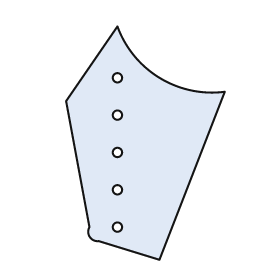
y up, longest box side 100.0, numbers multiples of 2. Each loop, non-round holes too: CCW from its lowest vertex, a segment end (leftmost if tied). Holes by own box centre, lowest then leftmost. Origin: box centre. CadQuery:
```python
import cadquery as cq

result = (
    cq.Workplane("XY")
    .moveTo(6.0, -50.0)
    .lineTo(34.0, 22.0)
    .threePointArc((6.0, 28.0), (-12.0, 50.0))
    .lineTo(-34.0, 18.0)
    .lineTo(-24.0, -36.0)
    .threePointArc((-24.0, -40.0), (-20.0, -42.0))
    .close()
    .moveTo(-12.0, -36.0)
    .circle(2.0)
    .moveTo(-12.0, -20.0)
    .circle(2.0)
    .moveTo(-12.0, -4.0)
    .circle(2.0)
    .moveTo(-12.0, 12.0)
    .circle(2.0)
    .moveTo(-12.0, 28.0)
    .circle(2.0)
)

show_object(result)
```